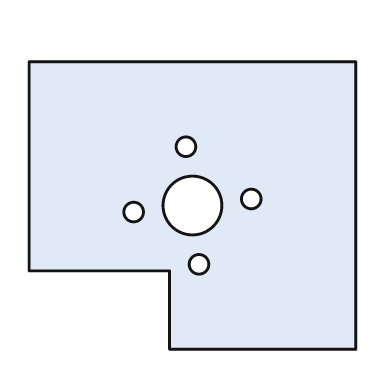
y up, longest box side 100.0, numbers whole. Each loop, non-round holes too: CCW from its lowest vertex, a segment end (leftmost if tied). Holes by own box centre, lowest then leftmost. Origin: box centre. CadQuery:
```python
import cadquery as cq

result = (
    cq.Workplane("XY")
    .moveTo(-7.0, -44.0)
    .lineTo(50.0, -44.0)
    .lineTo(50.0, 44.0)
    .lineTo(-50.0, 44.0)
    .lineTo(-50.0, -20.0)
    .lineTo(-7.0, -20.0)
    .close()
    .moveTo(2.0, -18.0)
    .circle(3.0)
    .moveTo(-18.0, -2.0)
    .circle(3.0)
    .moveTo(0.0, 0.0)
    .circle(9.0)
    .moveTo(18.0, 2.0)
    .circle(3.0)
    .moveTo(-2.0, 18.0)
    .circle(3.0)
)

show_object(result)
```